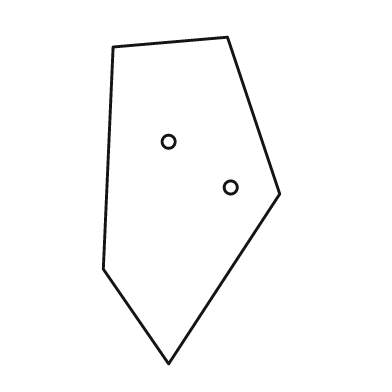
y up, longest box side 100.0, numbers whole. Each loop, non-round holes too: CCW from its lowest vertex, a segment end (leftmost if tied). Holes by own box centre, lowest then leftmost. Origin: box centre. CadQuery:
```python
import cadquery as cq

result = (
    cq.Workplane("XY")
    .moveTo(-7.0, -50.0)
    .lineTo(27.0, 2.0)
    .lineTo(11.0, 50.0)
    .lineTo(-24.0, 47.0)
    .lineTo(-27.0, -21.0)
    .close()
    .moveTo(12.0, 4.0)
    .circle(2.0)
    .moveTo(-7.0, 18.0)
    .circle(2.0)
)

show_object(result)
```